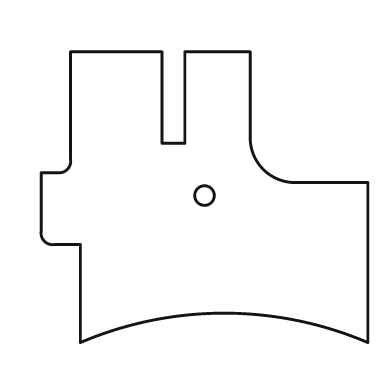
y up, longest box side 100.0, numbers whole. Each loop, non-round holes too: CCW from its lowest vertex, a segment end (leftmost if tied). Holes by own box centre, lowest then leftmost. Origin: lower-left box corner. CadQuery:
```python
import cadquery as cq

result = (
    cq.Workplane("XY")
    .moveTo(12.0, 0.0)
    .threePointArc((56.0, 9.0), (100.0, 0.0))
    .lineTo(100.0, 49.0)
    .lineTo(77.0, 49.0)
    .threePointArc((68.0, 53.0), (64.0, 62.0))
    .lineTo(64.0, 89.0)
    .lineTo(44.0, 89.0)
    .lineTo(44.0, 61.0)
    .lineTo(37.0, 61.0)
    .lineTo(37.0, 89.0)
    .lineTo(9.0, 89.0)
    .lineTo(9.0, 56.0)
    .threePointArc((8.0, 53.0), (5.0, 52.0))
    .lineTo(0.0, 52.0)
    .lineTo(0.0, 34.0)
    .threePointArc((1.0, 31.0), (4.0, 30.0))
    .lineTo(12.0, 30.0)
    .close()
    .moveTo(50.0, 45.0)
    .circle(3.0)
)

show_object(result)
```